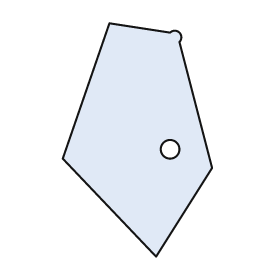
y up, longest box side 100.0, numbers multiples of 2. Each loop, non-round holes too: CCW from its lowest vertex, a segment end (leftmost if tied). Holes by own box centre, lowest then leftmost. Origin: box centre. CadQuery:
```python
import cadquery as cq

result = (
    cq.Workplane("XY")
    .moveTo(8.0, -50.0)
    .lineTo(32.0, -12.0)
    .lineTo(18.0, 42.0)
    .threePointArc((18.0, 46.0), (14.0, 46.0))
    .lineTo(-12.0, 50.0)
    .lineTo(-32.0, -8.0)
    .close()
    .moveTo(14.0, -4.0)
    .circle(4.0)
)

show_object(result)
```